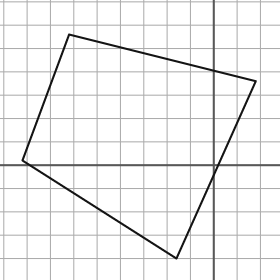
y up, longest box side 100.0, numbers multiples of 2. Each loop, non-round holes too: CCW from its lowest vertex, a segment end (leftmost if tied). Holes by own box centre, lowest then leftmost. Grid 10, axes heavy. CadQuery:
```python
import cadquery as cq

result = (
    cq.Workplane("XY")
    .moveTo(-16.0, -40.0)
    .lineTo(18.0, 36.0)
    .lineTo(-62.0, 56.0)
    .lineTo(-82.0, 2.0)
    .close()
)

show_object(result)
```